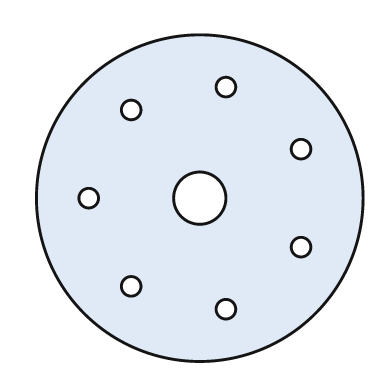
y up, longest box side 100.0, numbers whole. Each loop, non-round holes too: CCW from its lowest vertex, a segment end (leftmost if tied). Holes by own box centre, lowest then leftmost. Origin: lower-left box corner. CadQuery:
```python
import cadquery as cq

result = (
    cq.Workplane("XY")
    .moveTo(50.0, 50.0)
    .circle(50.0)
    .moveTo(58.0, 16.0)
    .circle(3.0)
    .moveTo(29.0, 23.0)
    .circle(3.0)
    .moveTo(81.0, 35.0)
    .circle(3.0)
    .moveTo(16.0, 50.0)
    .circle(3.0)
    .moveTo(50.0, 50.0)
    .circle(8.0)
    .moveTo(81.0, 65.0)
    .circle(3.0)
    .moveTo(29.0, 77.0)
    .circle(3.0)
    .moveTo(58.0, 84.0)
    .circle(3.0)
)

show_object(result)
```